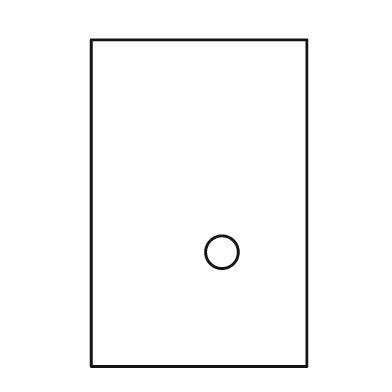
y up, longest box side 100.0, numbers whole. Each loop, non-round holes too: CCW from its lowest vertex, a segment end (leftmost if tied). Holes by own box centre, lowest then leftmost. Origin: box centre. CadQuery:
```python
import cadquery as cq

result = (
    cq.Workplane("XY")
    .moveTo(-33.0, -50.0)
    .lineTo(33.0, -50.0)
    .lineTo(33.0, 50.0)
    .lineTo(-33.0, 50.0)
    .close()
    .moveTo(7.0, -15.0)
    .circle(5.0)
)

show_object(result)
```